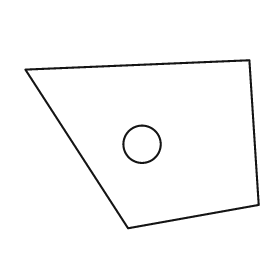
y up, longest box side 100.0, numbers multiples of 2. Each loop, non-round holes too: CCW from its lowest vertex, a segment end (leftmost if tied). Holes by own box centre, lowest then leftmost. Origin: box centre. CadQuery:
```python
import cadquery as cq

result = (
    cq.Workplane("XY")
    .moveTo(-6.0, -36.0)
    .lineTo(50.0, -26.0)
    .lineTo(46.0, 36.0)
    .lineTo(-50.0, 32.0)
    .close()
    .moveTo(0.0, 0.0)
    .circle(8.0)
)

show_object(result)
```